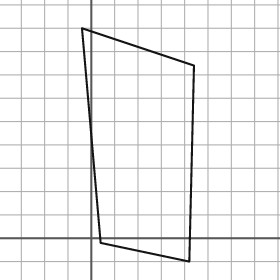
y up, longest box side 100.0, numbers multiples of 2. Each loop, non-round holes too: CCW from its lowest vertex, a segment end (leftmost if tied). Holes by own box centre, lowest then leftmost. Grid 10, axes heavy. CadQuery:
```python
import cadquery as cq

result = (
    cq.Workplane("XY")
    .moveTo(42.0, -10.0)
    .lineTo(44.0, 74.0)
    .lineTo(-4.0, 90.0)
    .lineTo(4.0, -2.0)
    .close()
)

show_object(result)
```